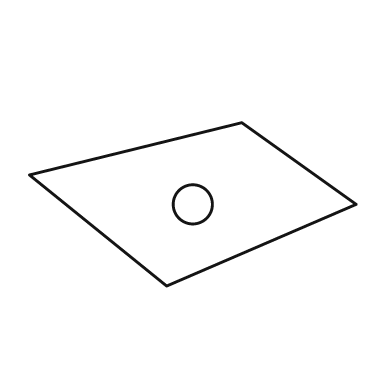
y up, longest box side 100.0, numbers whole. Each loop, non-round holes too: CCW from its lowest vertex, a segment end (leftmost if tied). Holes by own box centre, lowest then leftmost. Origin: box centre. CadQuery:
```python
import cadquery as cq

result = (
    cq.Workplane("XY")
    .moveTo(-8.0, -25.0)
    .lineTo(50.0, 0.0)
    .lineTo(15.0, 25.0)
    .lineTo(-50.0, 9.0)
    .close()
    .moveTo(0.0, 0.0)
    .circle(6.0)
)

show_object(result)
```